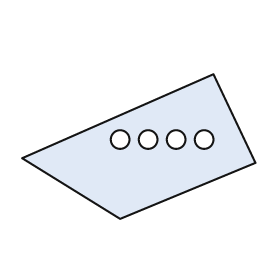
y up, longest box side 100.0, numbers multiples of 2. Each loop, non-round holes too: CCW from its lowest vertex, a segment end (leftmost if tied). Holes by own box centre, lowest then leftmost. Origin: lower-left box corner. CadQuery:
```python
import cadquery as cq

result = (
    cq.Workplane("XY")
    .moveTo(42.0, 0.0)
    .lineTo(100.0, 24.0)
    .lineTo(82.0, 62.0)
    .lineTo(0.0, 26.0)
    .close()
    .moveTo(42.0, 34.0)
    .circle(4.0)
    .moveTo(54.0, 34.0)
    .circle(4.0)
    .moveTo(66.0, 34.0)
    .circle(4.0)
    .moveTo(78.0, 34.0)
    .circle(4.0)
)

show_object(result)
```